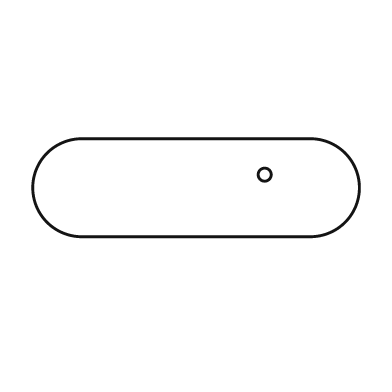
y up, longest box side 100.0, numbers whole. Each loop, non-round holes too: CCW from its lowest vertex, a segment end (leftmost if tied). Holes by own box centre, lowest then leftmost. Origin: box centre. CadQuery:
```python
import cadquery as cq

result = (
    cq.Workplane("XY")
    .moveTo(-35.0, -15.0)
    .lineTo(35.0, -15.0)
    .threePointArc((50.0, 0.0), (35.0, 15.0))
    .lineTo(-35.0, 15.0)
    .threePointArc((-50.0, 0.0), (-35.0, -15.0))
    .close()
    .moveTo(21.0, 4.0)
    .circle(2.0)
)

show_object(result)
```